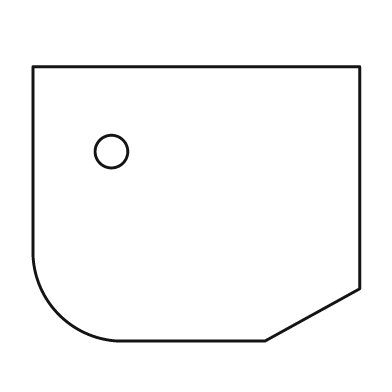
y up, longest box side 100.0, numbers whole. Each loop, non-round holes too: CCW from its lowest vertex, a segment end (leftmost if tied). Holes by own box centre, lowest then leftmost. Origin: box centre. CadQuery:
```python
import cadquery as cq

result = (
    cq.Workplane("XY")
    .moveTo(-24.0, -42.0)
    .lineTo(21.0, -42.0)
    .lineTo(50.0, -26.0)
    .lineTo(50.0, 42.0)
    .lineTo(-50.0, 42.0)
    .lineTo(-50.0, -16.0)
    .threePointArc((-42.0, -34.0), (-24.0, -42.0))
    .close()
    .moveTo(-26.0, 16.0)
    .circle(5.0)
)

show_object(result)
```